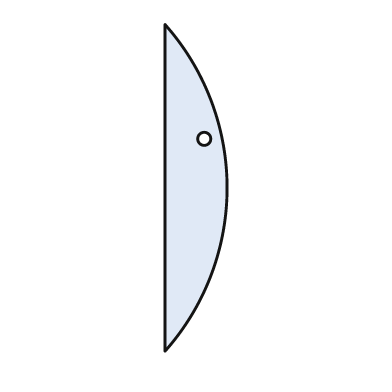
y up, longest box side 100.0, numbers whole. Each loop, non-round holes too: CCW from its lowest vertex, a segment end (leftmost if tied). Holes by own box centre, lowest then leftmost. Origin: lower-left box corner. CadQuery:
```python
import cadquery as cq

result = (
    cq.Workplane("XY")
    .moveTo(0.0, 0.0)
    .threePointArc((19.0, 50.0), (0.0, 100.0))
    .close()
    .moveTo(12.0, 65.0)
    .circle(2.0)
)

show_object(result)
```